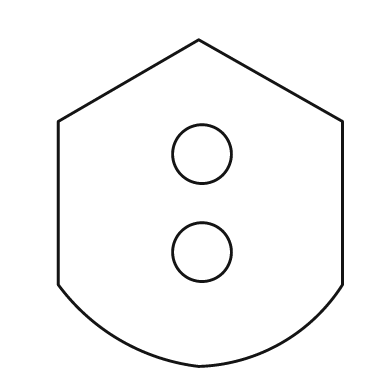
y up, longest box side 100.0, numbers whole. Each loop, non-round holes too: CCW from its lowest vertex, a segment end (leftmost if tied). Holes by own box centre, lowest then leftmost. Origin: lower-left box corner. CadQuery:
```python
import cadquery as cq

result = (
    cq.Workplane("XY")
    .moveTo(43.0, 0.0)
    .threePointArc((68.0, 7.0), (87.0, 25.0))
    .lineTo(87.0, 75.0)
    .lineTo(43.0, 100.0)
    .lineTo(0.0, 75.0)
    .lineTo(0.0, 25.0)
    .threePointArc((19.0, 8.0), (43.0, 0.0))
    .close()
    .moveTo(44.0, 35.0)
    .circle(9.0)
    .moveTo(44.0, 65.0)
    .circle(9.0)
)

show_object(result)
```